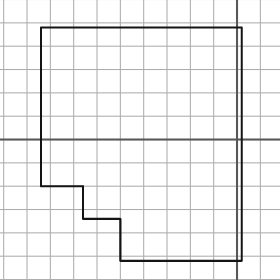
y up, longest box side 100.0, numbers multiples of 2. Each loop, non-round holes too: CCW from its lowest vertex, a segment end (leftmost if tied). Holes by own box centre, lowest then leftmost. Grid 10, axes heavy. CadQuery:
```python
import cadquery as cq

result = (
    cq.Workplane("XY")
    .moveTo(-50.0, -52.0)
    .lineTo(2.0, -52.0)
    .lineTo(2.0, 48.0)
    .lineTo(-84.0, 48.0)
    .lineTo(-84.0, -20.0)
    .lineTo(-66.0, -20.0)
    .lineTo(-66.0, -34.0)
    .lineTo(-50.0, -34.0)
    .close()
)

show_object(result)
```